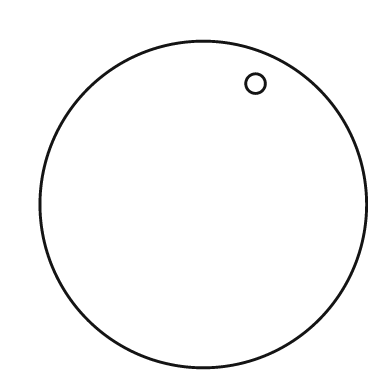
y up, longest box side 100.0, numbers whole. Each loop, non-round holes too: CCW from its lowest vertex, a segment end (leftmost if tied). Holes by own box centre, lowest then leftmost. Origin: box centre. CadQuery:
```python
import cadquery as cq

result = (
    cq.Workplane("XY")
    .moveTo(0.0, 0.0)
    .circle(50.0)
    .moveTo(16.0, 37.0)
    .circle(3.0)
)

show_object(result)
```